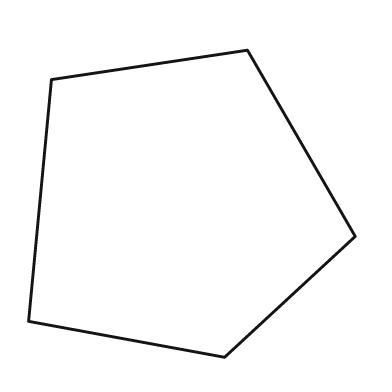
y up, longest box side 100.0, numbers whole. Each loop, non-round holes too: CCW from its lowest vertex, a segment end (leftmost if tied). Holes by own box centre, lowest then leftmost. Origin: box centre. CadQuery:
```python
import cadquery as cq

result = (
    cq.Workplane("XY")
    .moveTo(10.0, -47.0)
    .lineTo(50.0, -10.0)
    .lineTo(17.0, 47.0)
    .lineTo(-43.0, 38.0)
    .lineTo(-50.0, -36.0)
    .close()
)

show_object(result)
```